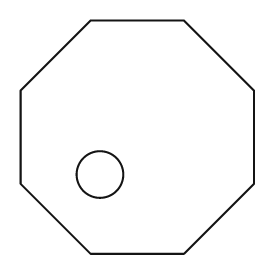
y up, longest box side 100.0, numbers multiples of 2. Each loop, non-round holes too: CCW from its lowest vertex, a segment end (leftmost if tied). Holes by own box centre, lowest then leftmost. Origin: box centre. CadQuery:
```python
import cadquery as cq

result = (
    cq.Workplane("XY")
    .moveTo(-20.0, -50.0)
    .lineTo(20.0, -50.0)
    .lineTo(50.0, -20.0)
    .lineTo(50.0, 20.0)
    .lineTo(20.0, 50.0)
    .lineTo(-20.0, 50.0)
    .lineTo(-50.0, 20.0)
    .lineTo(-50.0, -20.0)
    .close()
    .moveTo(-16.0, -16.0)
    .circle(10.0)
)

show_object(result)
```